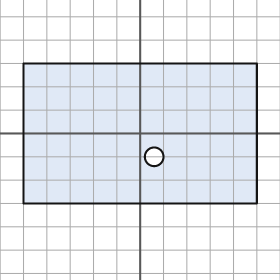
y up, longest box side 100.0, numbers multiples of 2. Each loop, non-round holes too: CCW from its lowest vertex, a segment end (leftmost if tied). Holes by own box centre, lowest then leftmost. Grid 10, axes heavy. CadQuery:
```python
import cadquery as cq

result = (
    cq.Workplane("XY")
    .moveTo(-50.0, -30.0)
    .lineTo(50.0, -30.0)
    .lineTo(50.0, 30.0)
    .lineTo(-50.0, 30.0)
    .close()
    .moveTo(6.0, -10.0)
    .circle(4.0)
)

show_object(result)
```